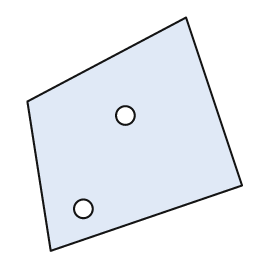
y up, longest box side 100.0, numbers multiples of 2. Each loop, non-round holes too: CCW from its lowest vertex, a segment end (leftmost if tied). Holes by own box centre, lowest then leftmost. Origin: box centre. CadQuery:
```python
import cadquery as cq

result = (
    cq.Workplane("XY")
    .moveTo(-36.0, -50.0)
    .lineTo(46.0, -22.0)
    .lineTo(22.0, 50.0)
    .lineTo(-46.0, 14.0)
    .close()
    .moveTo(-22.0, -32.0)
    .circle(4.0)
    .moveTo(-4.0, 8.0)
    .circle(4.0)
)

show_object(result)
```